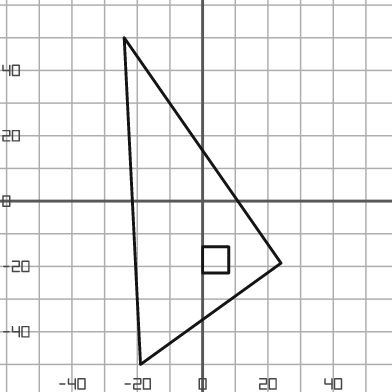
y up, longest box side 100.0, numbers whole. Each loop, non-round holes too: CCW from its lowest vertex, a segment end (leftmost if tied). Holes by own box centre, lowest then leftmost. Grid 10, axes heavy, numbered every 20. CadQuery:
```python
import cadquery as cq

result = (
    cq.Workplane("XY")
    .moveTo(-19.0, -50.0)
    .lineTo(24.0, -19.0)
    .lineTo(-24.0, 50.0)
    .close()
    .moveTo(0.0, -22.0)
    .lineTo(8.0, -22.0)
    .lineTo(8.0, -14.0)
    .lineTo(0.0, -14.0)
    .close()
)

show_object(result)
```